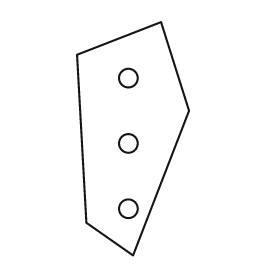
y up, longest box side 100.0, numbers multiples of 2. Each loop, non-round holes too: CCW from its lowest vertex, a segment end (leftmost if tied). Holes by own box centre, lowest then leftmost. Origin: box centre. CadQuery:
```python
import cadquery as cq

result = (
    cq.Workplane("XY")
    .moveTo(0.0, -50.0)
    .lineTo(24.0, 12.0)
    .lineTo(12.0, 50.0)
    .lineTo(-24.0, 36.0)
    .lineTo(-20.0, -36.0)
    .close()
    .moveTo(-2.0, -30.0)
    .circle(4.0)
    .moveTo(-2.0, -2.0)
    .circle(4.0)
    .moveTo(-2.0, 26.0)
    .circle(4.0)
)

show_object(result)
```